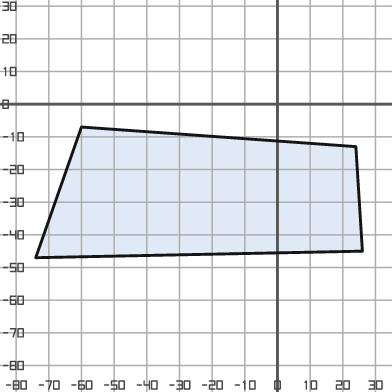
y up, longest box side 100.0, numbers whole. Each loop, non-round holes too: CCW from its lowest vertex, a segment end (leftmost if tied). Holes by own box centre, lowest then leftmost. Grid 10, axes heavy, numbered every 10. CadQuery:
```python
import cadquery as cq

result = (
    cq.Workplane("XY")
    .moveTo(-74.0, -47.0)
    .lineTo(26.0, -45.0)
    .lineTo(24.0, -13.0)
    .lineTo(-60.0, -7.0)
    .close()
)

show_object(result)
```